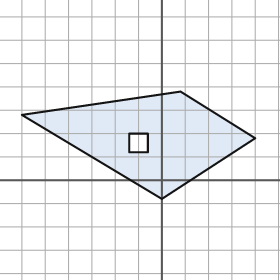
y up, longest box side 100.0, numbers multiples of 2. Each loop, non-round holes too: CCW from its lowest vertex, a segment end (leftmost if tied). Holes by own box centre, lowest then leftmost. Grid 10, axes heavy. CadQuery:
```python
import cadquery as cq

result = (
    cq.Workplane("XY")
    .moveTo(0.0, -8.0)
    .lineTo(40.0, 18.0)
    .lineTo(8.0, 38.0)
    .lineTo(-60.0, 28.0)
    .close()
    .moveTo(-14.0, 12.0)
    .lineTo(-6.0, 12.0)
    .lineTo(-6.0, 20.0)
    .lineTo(-14.0, 20.0)
    .close()
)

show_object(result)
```